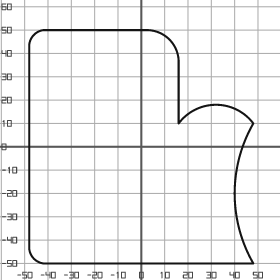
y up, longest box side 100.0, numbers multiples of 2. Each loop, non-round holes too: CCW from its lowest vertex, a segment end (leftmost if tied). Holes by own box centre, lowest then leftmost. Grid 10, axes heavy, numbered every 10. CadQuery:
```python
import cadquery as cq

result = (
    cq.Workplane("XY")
    .moveTo(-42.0, -50.0)
    .lineTo(48.0, -50.0)
    .threePointArc((40.0, -20.0), (48.0, 10.0))
    .threePointArc((32.0, 18.0), (16.0, 10.0))
    .lineTo(16.0, 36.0)
    .threePointArc((12.0, 46.0), (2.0, 50.0))
    .lineTo(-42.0, 50.0)
    .threePointArc((-46.0, 48.0), (-48.0, 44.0))
    .lineTo(-48.0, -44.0)
    .threePointArc((-46.0, -48.0), (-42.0, -50.0))
    .close()
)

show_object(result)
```